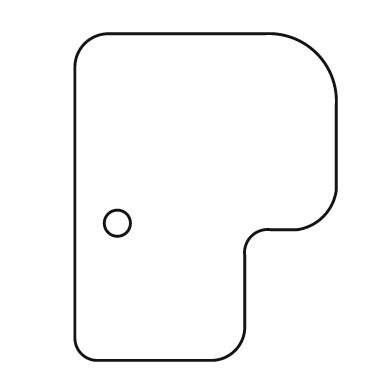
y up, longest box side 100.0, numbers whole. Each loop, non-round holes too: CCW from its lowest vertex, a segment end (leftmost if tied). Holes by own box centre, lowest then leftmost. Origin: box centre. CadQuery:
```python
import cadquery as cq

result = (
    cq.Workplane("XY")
    .moveTo(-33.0, -50.0)
    .lineTo(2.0, -50.0)
    .threePointArc((9.0, -47.0), (12.0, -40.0))
    .lineTo(12.0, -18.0)
    .threePointArc((14.0, -12.0), (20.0, -10.0))
    .lineTo(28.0, -10.0)
    .threePointArc((36.0, -6.0), (40.0, 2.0))
    .lineTo(40.0, 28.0)
    .threePointArc((34.0, 44.0), (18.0, 50.0))
    .lineTo(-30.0, 50.0)
    .threePointArc((-37.0, 47.0), (-40.0, 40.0))
    .lineTo(-40.0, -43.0)
    .threePointArc((-38.0, -48.0), (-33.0, -50.0))
    .close()
    .moveTo(-27.0, -8.0)
    .circle(4.0)
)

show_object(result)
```